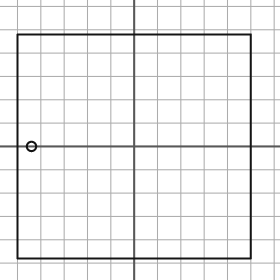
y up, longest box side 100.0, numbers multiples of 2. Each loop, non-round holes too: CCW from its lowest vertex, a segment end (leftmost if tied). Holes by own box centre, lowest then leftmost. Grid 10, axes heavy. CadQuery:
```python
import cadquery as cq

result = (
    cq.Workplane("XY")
    .moveTo(-50.0, -48.0)
    .lineTo(50.0, -48.0)
    .lineTo(50.0, 48.0)
    .lineTo(-50.0, 48.0)
    .close()
    .moveTo(-44.0, 0.0)
    .circle(2.0)
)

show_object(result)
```